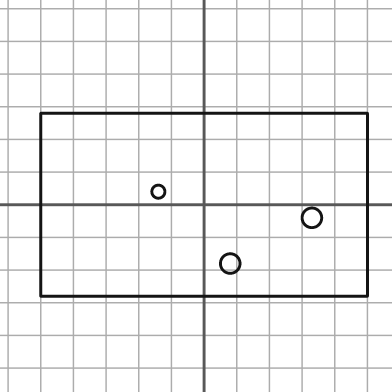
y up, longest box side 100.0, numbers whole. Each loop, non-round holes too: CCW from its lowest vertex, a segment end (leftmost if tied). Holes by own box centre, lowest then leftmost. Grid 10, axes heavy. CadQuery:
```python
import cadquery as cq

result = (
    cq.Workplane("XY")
    .moveTo(-50.0, -28.0)
    .lineTo(50.0, -28.0)
    .lineTo(50.0, 28.0)
    .lineTo(-50.0, 28.0)
    .close()
    .moveTo(8.0, -18.0)
    .circle(3.0)
    .moveTo(33.0, -4.0)
    .circle(3.0)
    .moveTo(-14.0, 4.0)
    .circle(2.0)
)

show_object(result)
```